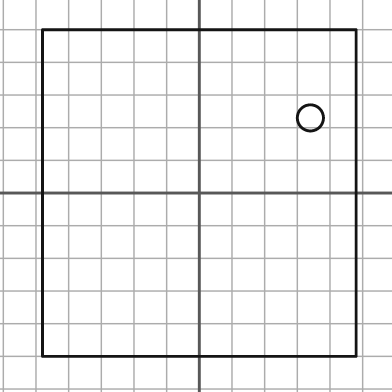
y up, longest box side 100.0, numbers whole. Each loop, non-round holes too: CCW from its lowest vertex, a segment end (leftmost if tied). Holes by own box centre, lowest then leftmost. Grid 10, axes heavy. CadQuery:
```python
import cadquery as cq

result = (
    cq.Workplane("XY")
    .moveTo(-48.0, -50.0)
    .lineTo(48.0, -50.0)
    .lineTo(48.0, 50.0)
    .lineTo(-48.0, 50.0)
    .close()
    .moveTo(34.0, 23.0)
    .circle(4.0)
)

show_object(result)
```